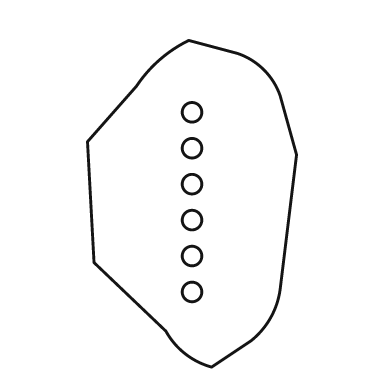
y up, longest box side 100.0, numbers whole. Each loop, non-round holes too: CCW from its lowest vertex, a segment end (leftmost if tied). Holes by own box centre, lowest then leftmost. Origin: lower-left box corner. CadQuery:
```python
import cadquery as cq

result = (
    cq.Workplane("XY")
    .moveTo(38.0, 0.0)
    .lineTo(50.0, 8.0)
    .threePointArc((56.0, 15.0), (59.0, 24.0))
    .lineTo(64.0, 65.0)
    .lineTo(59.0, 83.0)
    .threePointArc((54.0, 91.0), (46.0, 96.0))
    .lineTo(31.0, 100.0)
    .threePointArc((22.0, 94.0), (15.0, 86.0))
    .lineTo(0.0, 69.0)
    .lineTo(2.0, 32.0)
    .lineTo(24.0, 11.0)
    .threePointArc((30.0, 4.0), (38.0, 0.0))
    .close()
    .moveTo(32.0, 23.0)
    .circle(3.0)
    .moveTo(32.0, 34.0)
    .circle(3.0)
    .moveTo(32.0, 45.0)
    .circle(3.0)
    .moveTo(32.0, 56.0)
    .circle(3.0)
    .moveTo(32.0, 67.0)
    .circle(3.0)
    .moveTo(32.0, 78.0)
    .circle(3.0)
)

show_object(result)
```